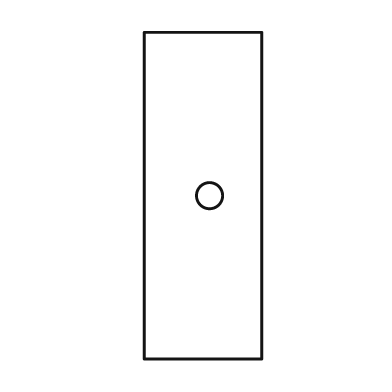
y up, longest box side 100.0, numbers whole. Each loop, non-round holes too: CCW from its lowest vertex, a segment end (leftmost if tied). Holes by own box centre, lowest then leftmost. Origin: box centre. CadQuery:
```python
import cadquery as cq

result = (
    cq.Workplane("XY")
    .moveTo(-18.0, -50.0)
    .lineTo(18.0, -50.0)
    .lineTo(18.0, 50.0)
    .lineTo(-18.0, 50.0)
    .close()
    .moveTo(2.0, 0.0)
    .circle(4.0)
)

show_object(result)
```